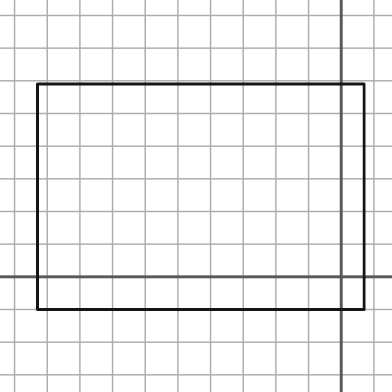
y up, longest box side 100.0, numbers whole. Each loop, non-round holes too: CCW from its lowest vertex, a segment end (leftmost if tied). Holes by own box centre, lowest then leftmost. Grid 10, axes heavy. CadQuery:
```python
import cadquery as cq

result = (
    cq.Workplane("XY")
    .moveTo(-93.0, -10.0)
    .lineTo(7.0, -10.0)
    .lineTo(7.0, 59.0)
    .lineTo(-93.0, 59.0)
    .close()
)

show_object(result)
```